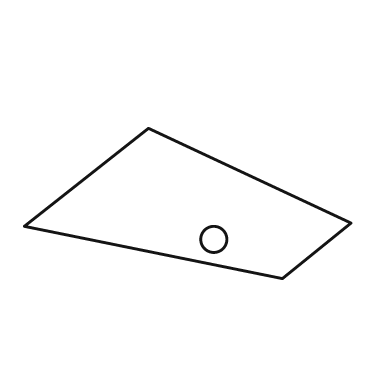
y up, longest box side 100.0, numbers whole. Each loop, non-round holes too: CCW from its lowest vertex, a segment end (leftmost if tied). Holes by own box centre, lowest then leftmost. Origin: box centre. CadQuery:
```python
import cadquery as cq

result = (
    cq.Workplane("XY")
    .moveTo(29.0, -23.0)
    .lineTo(50.0, -6.0)
    .lineTo(-12.0, 23.0)
    .lineTo(-50.0, -7.0)
    .close()
    .moveTo(8.0, -11.0)
    .circle(4.0)
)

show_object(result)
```